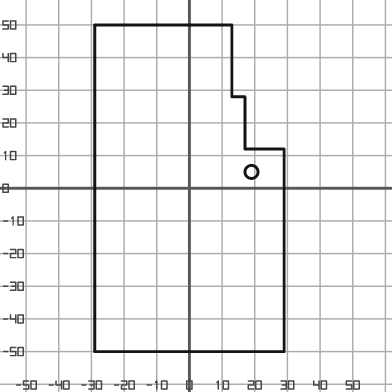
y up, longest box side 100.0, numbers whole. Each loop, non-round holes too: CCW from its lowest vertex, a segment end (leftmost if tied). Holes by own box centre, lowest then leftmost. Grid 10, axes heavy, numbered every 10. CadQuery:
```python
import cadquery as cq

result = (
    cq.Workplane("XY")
    .moveTo(-29.0, -50.0)
    .lineTo(29.0, -50.0)
    .lineTo(29.0, 12.0)
    .lineTo(17.0, 12.0)
    .lineTo(17.0, 28.0)
    .lineTo(13.0, 28.0)
    .lineTo(13.0, 50.0)
    .lineTo(-29.0, 50.0)
    .close()
    .moveTo(19.0, 5.0)
    .circle(2.0)
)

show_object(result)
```